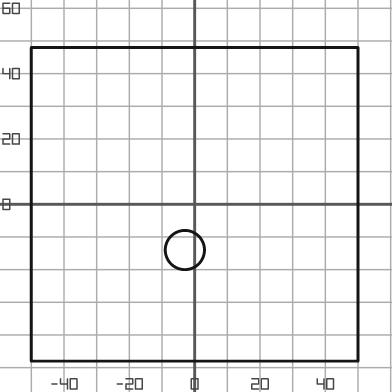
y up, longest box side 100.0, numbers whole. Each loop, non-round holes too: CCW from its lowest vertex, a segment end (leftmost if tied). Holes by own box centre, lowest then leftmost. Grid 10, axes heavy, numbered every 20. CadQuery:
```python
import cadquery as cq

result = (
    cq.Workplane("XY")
    .moveTo(-50.0, -48.0)
    .lineTo(50.0, -48.0)
    .lineTo(50.0, 48.0)
    .lineTo(-50.0, 48.0)
    .close()
    .moveTo(-3.0, -14.0)
    .circle(6.0)
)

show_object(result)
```